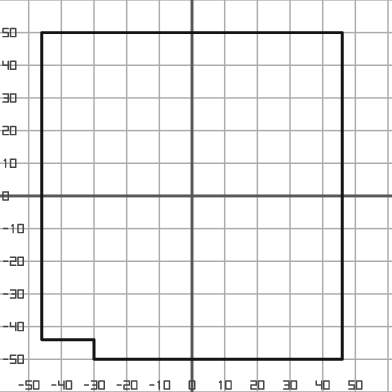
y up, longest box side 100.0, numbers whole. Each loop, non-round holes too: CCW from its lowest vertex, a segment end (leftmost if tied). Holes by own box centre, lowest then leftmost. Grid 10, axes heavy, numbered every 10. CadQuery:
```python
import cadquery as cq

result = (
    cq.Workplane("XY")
    .moveTo(-30.0, -50.0)
    .lineTo(46.0, -50.0)
    .lineTo(46.0, 50.0)
    .lineTo(-46.0, 50.0)
    .lineTo(-46.0, -44.0)
    .lineTo(-30.0, -44.0)
    .close()
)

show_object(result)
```